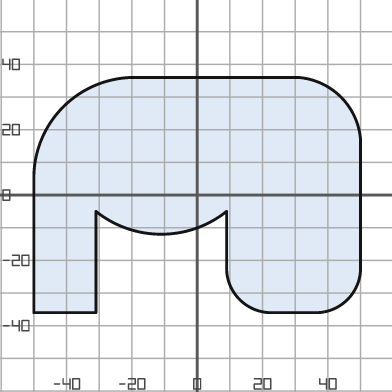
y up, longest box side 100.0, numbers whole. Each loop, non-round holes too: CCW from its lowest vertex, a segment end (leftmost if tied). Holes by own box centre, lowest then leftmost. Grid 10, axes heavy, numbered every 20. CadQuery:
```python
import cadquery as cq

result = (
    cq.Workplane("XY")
    .moveTo(-50.0, -36.0)
    .lineTo(-31.0, -36.0)
    .lineTo(-31.0, -5.0)
    .threePointArc((-11.0, -12.0), (9.0, -5.0))
    .lineTo(9.0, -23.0)
    .threePointArc((13.0, -32.0), (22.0, -36.0))
    .lineTo(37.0, -36.0)
    .threePointArc((46.0, -32.0), (50.0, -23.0))
    .lineTo(50.0, 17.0)
    .threePointArc((44.0, 30.0), (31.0, 36.0))
    .lineTo(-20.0, 36.0)
    .threePointArc((-41.0, 27.0), (-50.0, 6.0))
    .close()
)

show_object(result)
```